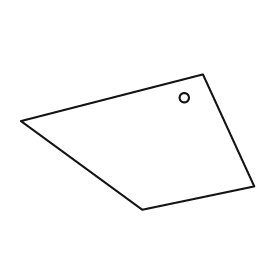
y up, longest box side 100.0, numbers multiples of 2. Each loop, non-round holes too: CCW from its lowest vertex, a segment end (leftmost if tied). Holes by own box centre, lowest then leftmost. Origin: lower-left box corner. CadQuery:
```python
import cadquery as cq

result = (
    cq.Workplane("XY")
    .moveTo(52.0, 0.0)
    .lineTo(100.0, 10.0)
    .lineTo(78.0, 58.0)
    .lineTo(0.0, 38.0)
    .close()
    .moveTo(70.0, 48.0)
    .circle(2.0)
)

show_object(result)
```